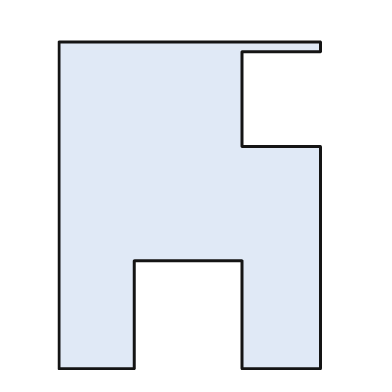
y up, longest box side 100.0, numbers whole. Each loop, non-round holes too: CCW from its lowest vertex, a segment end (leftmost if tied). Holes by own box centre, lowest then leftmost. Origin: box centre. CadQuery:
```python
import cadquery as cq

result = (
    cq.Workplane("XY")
    .moveTo(-40.0, -50.0)
    .lineTo(-17.0, -50.0)
    .lineTo(-17.0, -17.0)
    .lineTo(16.0, -17.0)
    .lineTo(16.0, -50.0)
    .lineTo(40.0, -50.0)
    .lineTo(40.0, 18.0)
    .lineTo(16.0, 18.0)
    .lineTo(16.0, 47.0)
    .lineTo(40.0, 47.0)
    .lineTo(40.0, 50.0)
    .lineTo(-40.0, 50.0)
    .close()
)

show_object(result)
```